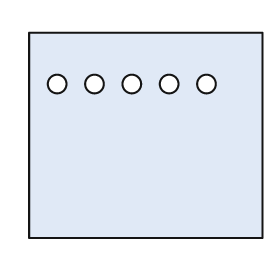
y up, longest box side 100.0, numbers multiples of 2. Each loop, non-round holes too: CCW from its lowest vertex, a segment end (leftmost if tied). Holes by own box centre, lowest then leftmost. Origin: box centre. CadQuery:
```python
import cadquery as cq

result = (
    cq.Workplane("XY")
    .moveTo(-50.0, -44.0)
    .lineTo(50.0, -44.0)
    .lineTo(50.0, 44.0)
    .lineTo(-50.0, 44.0)
    .close()
    .moveTo(-38.0, 22.0)
    .circle(4.0)
    .moveTo(-22.0, 22.0)
    .circle(4.0)
    .moveTo(-6.0, 22.0)
    .circle(4.0)
    .moveTo(10.0, 22.0)
    .circle(4.0)
    .moveTo(26.0, 22.0)
    .circle(4.0)
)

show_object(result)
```